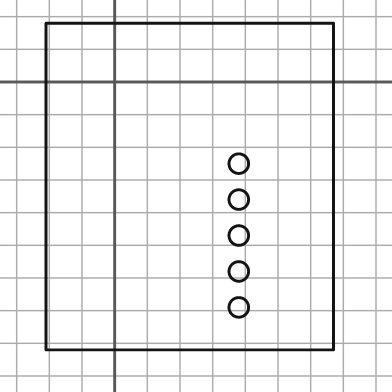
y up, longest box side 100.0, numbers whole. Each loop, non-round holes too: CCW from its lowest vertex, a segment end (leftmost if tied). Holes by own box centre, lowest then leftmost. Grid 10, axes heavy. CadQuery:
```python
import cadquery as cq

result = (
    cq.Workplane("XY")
    .moveTo(-21.0, -82.0)
    .lineTo(67.0, -82.0)
    .lineTo(67.0, 18.0)
    .lineTo(-21.0, 18.0)
    .close()
    .moveTo(38.0, -69.0)
    .circle(3.0)
    .moveTo(38.0, -58.0)
    .circle(3.0)
    .moveTo(38.0, -47.0)
    .circle(3.0)
    .moveTo(38.0, -36.0)
    .circle(3.0)
    .moveTo(38.0, -25.0)
    .circle(3.0)
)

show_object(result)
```